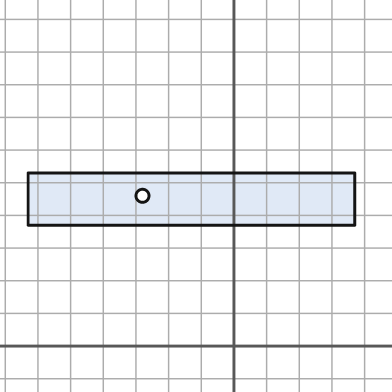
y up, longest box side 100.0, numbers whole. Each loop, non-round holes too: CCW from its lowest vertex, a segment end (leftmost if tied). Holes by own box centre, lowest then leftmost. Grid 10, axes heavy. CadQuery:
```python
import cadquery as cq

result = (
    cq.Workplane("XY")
    .moveTo(-63.0, 37.0)
    .lineTo(37.0, 37.0)
    .lineTo(37.0, 53.0)
    .lineTo(-63.0, 53.0)
    .close()
    .moveTo(-28.0, 46.0)
    .circle(2.0)
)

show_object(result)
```